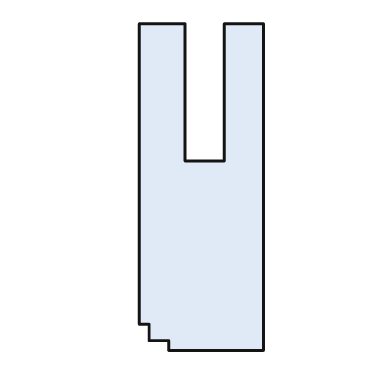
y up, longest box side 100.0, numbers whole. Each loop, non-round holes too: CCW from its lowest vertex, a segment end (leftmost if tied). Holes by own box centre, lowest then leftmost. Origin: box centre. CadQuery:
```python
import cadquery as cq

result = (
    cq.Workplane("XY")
    .moveTo(-10.0, -50.0)
    .lineTo(19.0, -50.0)
    .lineTo(19.0, 50.0)
    .lineTo(7.0, 50.0)
    .lineTo(7.0, 8.0)
    .lineTo(-5.0, 8.0)
    .lineTo(-5.0, 50.0)
    .lineTo(-19.0, 50.0)
    .lineTo(-19.0, -42.0)
    .lineTo(-16.0, -42.0)
    .lineTo(-16.0, -47.0)
    .lineTo(-10.0, -47.0)
    .close()
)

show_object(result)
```